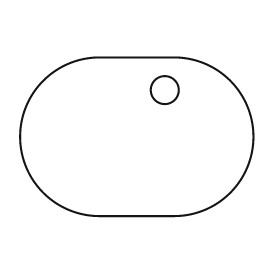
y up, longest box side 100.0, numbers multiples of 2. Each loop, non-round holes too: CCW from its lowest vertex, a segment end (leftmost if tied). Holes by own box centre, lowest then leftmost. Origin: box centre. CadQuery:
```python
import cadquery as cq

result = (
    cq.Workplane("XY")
    .moveTo(-16.0, -34.0)
    .lineTo(16.0, -34.0)
    .threePointArc((50.0, 0.0), (16.0, 34.0))
    .lineTo(-16.0, 34.0)
    .threePointArc((-50.0, 0.0), (-16.0, -34.0))
    .close()
    .moveTo(12.0, 20.0)
    .circle(6.0)
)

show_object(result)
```